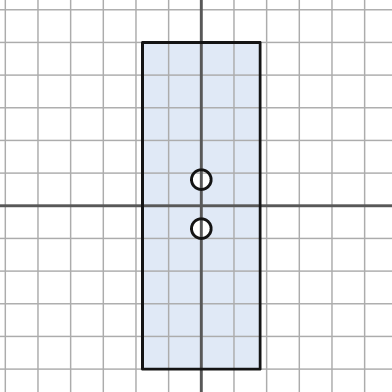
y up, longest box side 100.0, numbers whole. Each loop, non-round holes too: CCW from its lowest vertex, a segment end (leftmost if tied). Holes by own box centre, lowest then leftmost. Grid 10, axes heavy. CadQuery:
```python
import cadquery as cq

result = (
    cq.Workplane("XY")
    .moveTo(-18.0, -50.0)
    .lineTo(18.0, -50.0)
    .lineTo(18.0, 50.0)
    .lineTo(-18.0, 50.0)
    .close()
    .moveTo(0.0, -7.0)
    .circle(3.0)
    .moveTo(0.0, 8.0)
    .circle(3.0)
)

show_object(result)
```